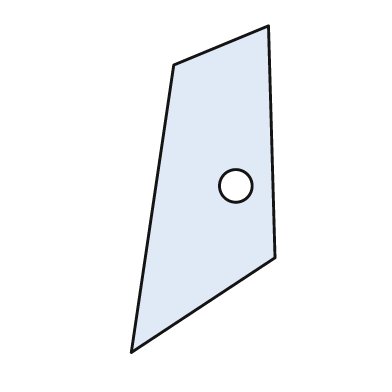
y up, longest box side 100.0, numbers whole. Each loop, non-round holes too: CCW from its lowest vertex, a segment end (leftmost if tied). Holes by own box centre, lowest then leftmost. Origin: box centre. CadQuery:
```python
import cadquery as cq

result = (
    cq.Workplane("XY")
    .moveTo(-22.0, -50.0)
    .lineTo(22.0, -21.0)
    .lineTo(20.0, 50.0)
    .lineTo(-9.0, 38.0)
    .close()
    .moveTo(10.0, 1.0)
    .circle(5.0)
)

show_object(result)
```